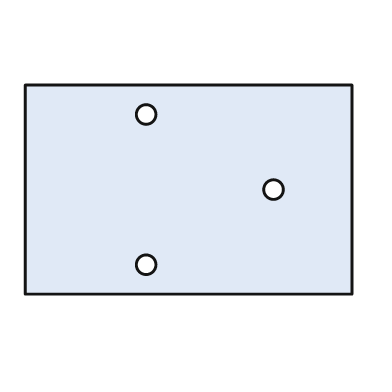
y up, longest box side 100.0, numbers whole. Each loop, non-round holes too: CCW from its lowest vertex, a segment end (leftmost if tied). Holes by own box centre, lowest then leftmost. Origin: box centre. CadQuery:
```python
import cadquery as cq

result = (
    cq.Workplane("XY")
    .moveTo(-50.0, -32.0)
    .lineTo(50.0, -32.0)
    .lineTo(50.0, 32.0)
    .lineTo(-50.0, 32.0)
    .close()
    .moveTo(-13.0, -23.0)
    .circle(3.0)
    .moveTo(26.0, 0.0)
    .circle(3.0)
    .moveTo(-13.0, 23.0)
    .circle(3.0)
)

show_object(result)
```